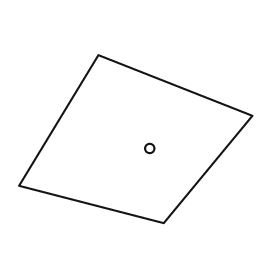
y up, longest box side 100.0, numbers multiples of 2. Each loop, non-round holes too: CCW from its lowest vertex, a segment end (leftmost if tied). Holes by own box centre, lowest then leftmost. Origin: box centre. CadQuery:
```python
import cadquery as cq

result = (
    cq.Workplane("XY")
    .moveTo(12.0, -36.0)
    .lineTo(50.0, 10.0)
    .lineTo(-16.0, 36.0)
    .lineTo(-50.0, -20.0)
    .close()
    .moveTo(6.0, -4.0)
    .circle(2.0)
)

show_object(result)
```